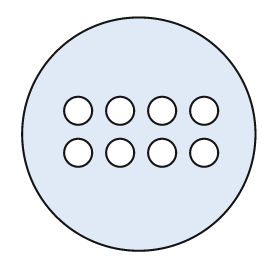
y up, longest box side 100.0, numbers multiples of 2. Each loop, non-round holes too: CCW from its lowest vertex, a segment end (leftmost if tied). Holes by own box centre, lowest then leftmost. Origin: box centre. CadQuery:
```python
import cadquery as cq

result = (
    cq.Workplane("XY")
    .moveTo(0.0, 0.0)
    .circle(50.0)
    .moveTo(-26.0, -8.0)
    .circle(6.0)
    .moveTo(-8.0, -8.0)
    .circle(6.0)
    .moveTo(10.0, -8.0)
    .circle(6.0)
    .moveTo(28.0, -8.0)
    .circle(6.0)
    .moveTo(-26.0, 10.0)
    .circle(6.0)
    .moveTo(-8.0, 10.0)
    .circle(6.0)
    .moveTo(10.0, 10.0)
    .circle(6.0)
    .moveTo(28.0, 10.0)
    .circle(6.0)
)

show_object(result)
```